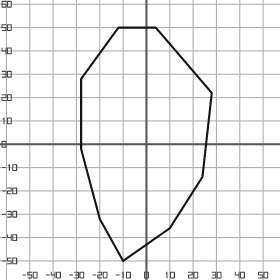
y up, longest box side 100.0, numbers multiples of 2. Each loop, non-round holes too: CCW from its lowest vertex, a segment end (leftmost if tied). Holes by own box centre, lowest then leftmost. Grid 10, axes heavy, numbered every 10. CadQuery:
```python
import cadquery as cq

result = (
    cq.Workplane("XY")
    .moveTo(-10.0, -50.0)
    .lineTo(10.0, -36.0)
    .lineTo(24.0, -14.0)
    .lineTo(28.0, 22.0)
    .lineTo(4.0, 50.0)
    .lineTo(-12.0, 50.0)
    .lineTo(-28.0, 28.0)
    .lineTo(-28.0, -2.0)
    .lineTo(-20.0, -32.0)
    .close()
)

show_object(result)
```